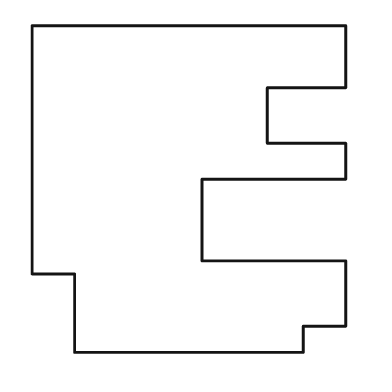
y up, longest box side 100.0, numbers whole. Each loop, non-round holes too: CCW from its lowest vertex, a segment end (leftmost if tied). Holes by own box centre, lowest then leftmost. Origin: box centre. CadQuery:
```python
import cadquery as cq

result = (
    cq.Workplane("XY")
    .moveTo(-35.0, -50.0)
    .lineTo(35.0, -50.0)
    .lineTo(35.0, -42.0)
    .lineTo(48.0, -42.0)
    .lineTo(48.0, -22.0)
    .lineTo(4.0, -22.0)
    .lineTo(4.0, 3.0)
    .lineTo(48.0, 3.0)
    .lineTo(48.0, 14.0)
    .lineTo(24.0, 14.0)
    .lineTo(24.0, 31.0)
    .lineTo(48.0, 31.0)
    .lineTo(48.0, 50.0)
    .lineTo(-48.0, 50.0)
    .lineTo(-48.0, -26.0)
    .lineTo(-35.0, -26.0)
    .close()
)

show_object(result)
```